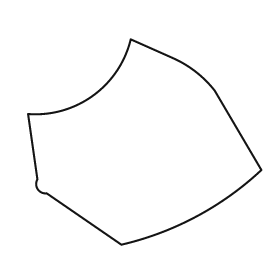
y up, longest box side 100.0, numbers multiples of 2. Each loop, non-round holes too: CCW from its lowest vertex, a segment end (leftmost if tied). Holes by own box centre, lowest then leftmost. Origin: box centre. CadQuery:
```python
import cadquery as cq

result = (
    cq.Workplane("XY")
    .moveTo(-10.0, -44.0)
    .threePointArc((22.0, -32.0), (50.0, -12.0))
    .lineTo(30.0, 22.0)
    .threePointArc((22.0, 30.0), (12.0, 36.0))
    .lineTo(-6.0, 44.0)
    .threePointArc((-22.0, 20.0), (-50.0, 12.0))
    .lineTo(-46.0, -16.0)
    .threePointArc((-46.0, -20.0), (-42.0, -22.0))
    .close()
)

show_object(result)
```